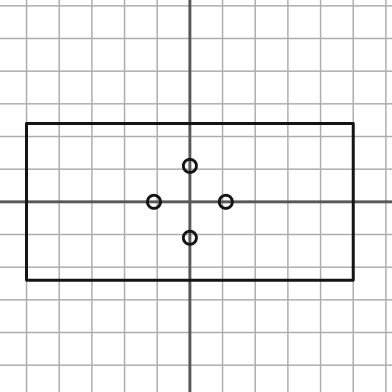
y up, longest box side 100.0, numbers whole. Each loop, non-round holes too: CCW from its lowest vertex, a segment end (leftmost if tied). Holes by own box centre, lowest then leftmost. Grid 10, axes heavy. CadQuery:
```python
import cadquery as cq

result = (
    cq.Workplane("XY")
    .moveTo(-50.0, -24.0)
    .lineTo(50.0, -24.0)
    .lineTo(50.0, 24.0)
    .lineTo(-50.0, 24.0)
    .close()
    .moveTo(0.0, -11.0)
    .circle(2.0)
    .moveTo(-11.0, 0.0)
    .circle(2.0)
    .moveTo(11.0, 0.0)
    .circle(2.0)
    .moveTo(0.0, 11.0)
    .circle(2.0)
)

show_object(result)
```